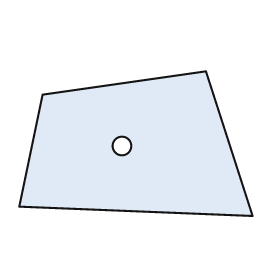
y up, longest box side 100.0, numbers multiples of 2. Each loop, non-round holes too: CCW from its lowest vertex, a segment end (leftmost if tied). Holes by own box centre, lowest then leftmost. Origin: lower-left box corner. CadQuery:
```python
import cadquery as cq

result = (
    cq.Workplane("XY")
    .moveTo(100.0, 0.0)
    .lineTo(80.0, 62.0)
    .lineTo(10.0, 52.0)
    .lineTo(0.0, 4.0)
    .close()
    .moveTo(44.0, 30.0)
    .circle(4.0)
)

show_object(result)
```